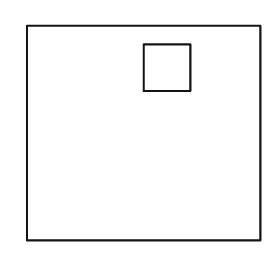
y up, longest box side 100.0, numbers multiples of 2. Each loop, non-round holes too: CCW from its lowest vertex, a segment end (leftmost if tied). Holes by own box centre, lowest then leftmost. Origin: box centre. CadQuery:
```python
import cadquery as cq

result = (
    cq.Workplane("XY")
    .moveTo(-50.0, -46.0)
    .lineTo(50.0, -46.0)
    .lineTo(50.0, 46.0)
    .lineTo(-50.0, 46.0)
    .close()
    .moveTo(0.0, 18.0)
    .lineTo(20.0, 18.0)
    .lineTo(20.0, 38.0)
    .lineTo(0.0, 38.0)
    .close()
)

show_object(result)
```